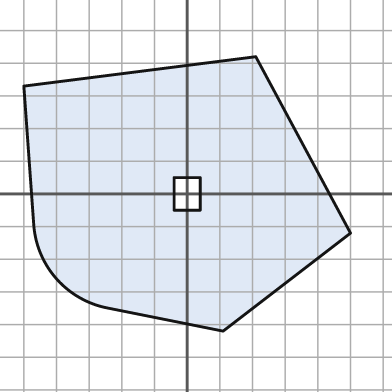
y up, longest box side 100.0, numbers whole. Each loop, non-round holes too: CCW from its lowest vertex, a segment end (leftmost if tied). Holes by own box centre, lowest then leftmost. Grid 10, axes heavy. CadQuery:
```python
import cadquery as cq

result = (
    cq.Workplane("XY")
    .moveTo(11.0, -42.0)
    .lineTo(50.0, -12.0)
    .lineTo(21.0, 42.0)
    .lineTo(-50.0, 33.0)
    .lineTo(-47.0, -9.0)
    .threePointArc((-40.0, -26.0), (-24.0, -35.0))
    .close()
    .moveTo(-4.0, -5.0)
    .lineTo(4.0, -5.0)
    .lineTo(4.0, 5.0)
    .lineTo(-4.0, 5.0)
    .close()
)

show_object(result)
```